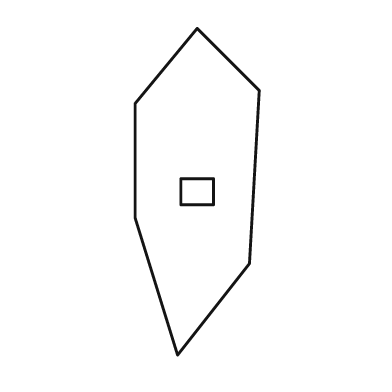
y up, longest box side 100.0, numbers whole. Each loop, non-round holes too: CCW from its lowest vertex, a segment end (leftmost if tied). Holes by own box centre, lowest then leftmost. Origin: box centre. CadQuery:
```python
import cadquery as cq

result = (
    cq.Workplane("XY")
    .moveTo(-6.0, -50.0)
    .lineTo(16.0, -22.0)
    .lineTo(19.0, 31.0)
    .lineTo(0.0, 50.0)
    .lineTo(-19.0, 27.0)
    .lineTo(-19.0, -8.0)
    .close()
    .moveTo(-5.0, -4.0)
    .lineTo(5.0, -4.0)
    .lineTo(5.0, 4.0)
    .lineTo(-5.0, 4.0)
    .close()
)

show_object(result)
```